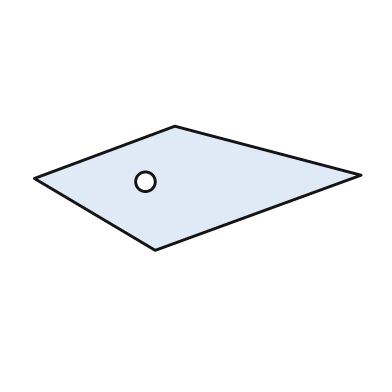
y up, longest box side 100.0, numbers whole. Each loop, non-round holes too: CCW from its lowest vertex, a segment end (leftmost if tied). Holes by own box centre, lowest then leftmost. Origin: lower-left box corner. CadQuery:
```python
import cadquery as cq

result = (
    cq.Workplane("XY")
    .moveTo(37.0, 0.0)
    .lineTo(100.0, 23.0)
    .lineTo(43.0, 38.0)
    .lineTo(0.0, 22.0)
    .close()
    .moveTo(34.0, 21.0)
    .circle(3.0)
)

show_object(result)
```